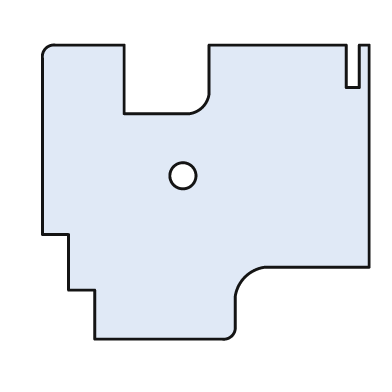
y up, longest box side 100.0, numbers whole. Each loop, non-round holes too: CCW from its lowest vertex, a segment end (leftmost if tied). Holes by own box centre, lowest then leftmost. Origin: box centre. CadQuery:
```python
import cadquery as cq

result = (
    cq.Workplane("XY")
    .moveTo(-34.0, -45.0)
    .lineTo(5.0, -45.0)
    .threePointArc((8.0, -44.0), (9.0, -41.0))
    .lineTo(9.0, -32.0)
    .threePointArc((12.0, -26.0), (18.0, -23.0))
    .lineTo(50.0, -23.0)
    .lineTo(50.0, 45.0)
    .lineTo(47.0, 45.0)
    .lineTo(47.0, 32.0)
    .lineTo(43.0, 32.0)
    .lineTo(43.0, 45.0)
    .lineTo(1.0, 45.0)
    .lineTo(1.0, 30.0)
    .threePointArc((-1.0, 26.0), (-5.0, 24.0))
    .lineTo(-25.0, 24.0)
    .lineTo(-25.0, 45.0)
    .lineTo(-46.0, 45.0)
    .threePointArc((-49.0, 44.0), (-50.0, 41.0))
    .lineTo(-50.0, -13.0)
    .lineTo(-42.0, -13.0)
    .lineTo(-42.0, -30.0)
    .lineTo(-34.0, -30.0)
    .close()
    .moveTo(-7.0, 5.0)
    .circle(4.0)
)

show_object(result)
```